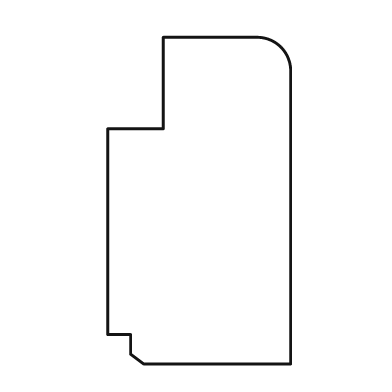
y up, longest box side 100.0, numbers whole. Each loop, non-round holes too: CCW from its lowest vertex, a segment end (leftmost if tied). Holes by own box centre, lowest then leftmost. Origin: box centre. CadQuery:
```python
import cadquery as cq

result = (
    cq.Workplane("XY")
    .moveTo(-17.0, -50.0)
    .lineTo(28.0, -50.0)
    .lineTo(28.0, 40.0)
    .threePointArc((25.0, 47.0), (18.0, 50.0))
    .lineTo(-11.0, 50.0)
    .lineTo(-11.0, 22.0)
    .lineTo(-28.0, 22.0)
    .lineTo(-28.0, -41.0)
    .lineTo(-21.0, -41.0)
    .lineTo(-21.0, -47.0)
    .close()
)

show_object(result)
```